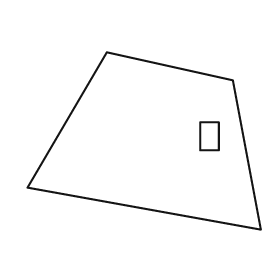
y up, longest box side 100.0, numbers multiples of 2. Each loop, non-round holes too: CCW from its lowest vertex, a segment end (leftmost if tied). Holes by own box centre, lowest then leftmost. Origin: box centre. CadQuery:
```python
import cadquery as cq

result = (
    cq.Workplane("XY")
    .moveTo(50.0, -38.0)
    .lineTo(38.0, 26.0)
    .lineTo(-16.0, 38.0)
    .lineTo(-50.0, -20.0)
    .close()
    .moveTo(24.0, -4.0)
    .lineTo(32.0, -4.0)
    .lineTo(32.0, 8.0)
    .lineTo(24.0, 8.0)
    .close()
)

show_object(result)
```